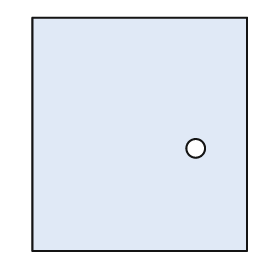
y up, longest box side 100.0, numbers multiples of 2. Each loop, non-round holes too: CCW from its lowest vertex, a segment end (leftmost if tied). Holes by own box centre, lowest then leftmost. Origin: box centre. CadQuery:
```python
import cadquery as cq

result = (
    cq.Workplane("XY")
    .moveTo(-46.0, -50.0)
    .lineTo(46.0, -50.0)
    .lineTo(46.0, 50.0)
    .lineTo(-46.0, 50.0)
    .close()
    .moveTo(24.0, -6.0)
    .circle(4.0)
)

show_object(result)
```